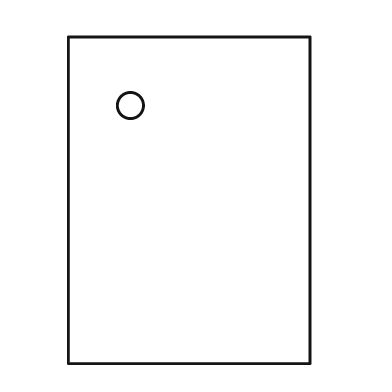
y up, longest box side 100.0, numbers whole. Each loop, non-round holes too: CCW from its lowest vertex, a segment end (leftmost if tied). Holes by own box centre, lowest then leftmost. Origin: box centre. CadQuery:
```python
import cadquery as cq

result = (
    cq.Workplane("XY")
    .moveTo(-37.0, -50.0)
    .lineTo(37.0, -50.0)
    .lineTo(37.0, 50.0)
    .lineTo(-37.0, 50.0)
    .close()
    .moveTo(-18.0, 29.0)
    .circle(4.0)
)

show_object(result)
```